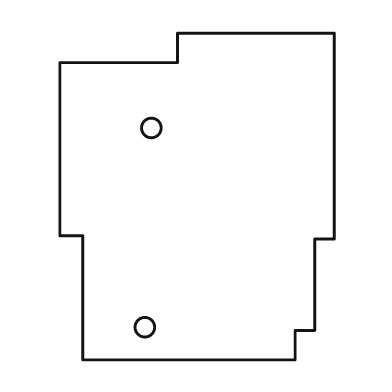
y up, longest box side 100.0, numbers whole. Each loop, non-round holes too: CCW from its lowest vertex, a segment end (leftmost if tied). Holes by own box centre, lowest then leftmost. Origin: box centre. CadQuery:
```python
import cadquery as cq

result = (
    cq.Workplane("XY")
    .moveTo(-35.0, -50.0)
    .lineTo(30.0, -50.0)
    .lineTo(30.0, -41.0)
    .lineTo(36.0, -41.0)
    .lineTo(36.0, -13.0)
    .lineTo(42.0, -13.0)
    .lineTo(42.0, 50.0)
    .lineTo(-6.0, 50.0)
    .lineTo(-6.0, 41.0)
    .lineTo(-42.0, 41.0)
    .lineTo(-42.0, -12.0)
    .lineTo(-35.0, -12.0)
    .close()
    .moveTo(-16.0, -40.0)
    .circle(3.0)
    .moveTo(-14.0, 21.0)
    .circle(3.0)
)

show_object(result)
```